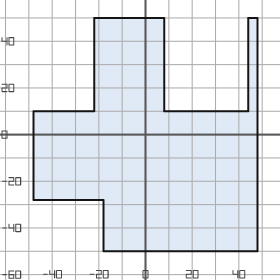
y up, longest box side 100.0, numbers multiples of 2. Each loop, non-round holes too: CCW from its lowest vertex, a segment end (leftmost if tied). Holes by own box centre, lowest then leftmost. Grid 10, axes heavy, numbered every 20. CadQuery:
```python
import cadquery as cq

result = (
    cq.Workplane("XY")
    .moveTo(-18.0, -50.0)
    .lineTo(48.0, -50.0)
    .lineTo(48.0, 50.0)
    .lineTo(44.0, 50.0)
    .lineTo(44.0, 10.0)
    .lineTo(8.0, 10.0)
    .lineTo(8.0, 50.0)
    .lineTo(-22.0, 50.0)
    .lineTo(-22.0, 10.0)
    .lineTo(-48.0, 10.0)
    .lineTo(-48.0, -28.0)
    .lineTo(-18.0, -28.0)
    .close()
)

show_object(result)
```